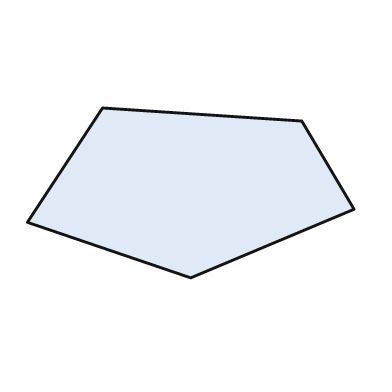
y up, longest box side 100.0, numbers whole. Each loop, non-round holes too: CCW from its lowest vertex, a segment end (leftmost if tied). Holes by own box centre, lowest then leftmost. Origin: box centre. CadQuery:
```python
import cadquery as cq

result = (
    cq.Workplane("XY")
    .moveTo(0.0, -26.0)
    .lineTo(50.0, -5.0)
    .lineTo(34.0, 22.0)
    .lineTo(-27.0, 26.0)
    .lineTo(-50.0, -9.0)
    .close()
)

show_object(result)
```